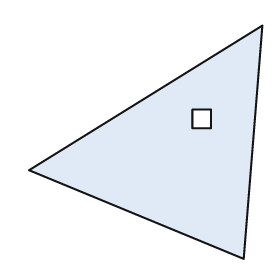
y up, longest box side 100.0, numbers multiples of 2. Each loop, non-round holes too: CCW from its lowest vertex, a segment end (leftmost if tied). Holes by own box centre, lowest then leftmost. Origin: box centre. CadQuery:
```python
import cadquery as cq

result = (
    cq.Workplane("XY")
    .moveTo(42.0, -50.0)
    .lineTo(50.0, 50.0)
    .lineTo(-50.0, -12.0)
    .close()
    .moveTo(20.0, 6.0)
    .lineTo(28.0, 6.0)
    .lineTo(28.0, 14.0)
    .lineTo(20.0, 14.0)
    .close()
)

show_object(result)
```